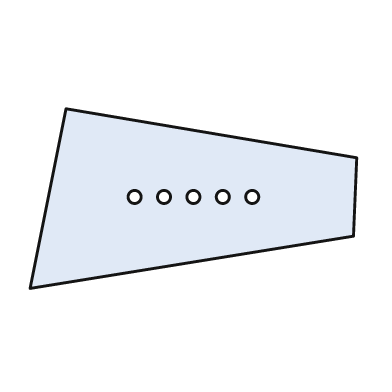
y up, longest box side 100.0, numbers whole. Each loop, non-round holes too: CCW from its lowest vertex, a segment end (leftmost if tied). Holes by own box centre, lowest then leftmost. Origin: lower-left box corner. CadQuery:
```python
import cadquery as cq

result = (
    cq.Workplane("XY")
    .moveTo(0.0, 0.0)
    .lineTo(99.0, 16.0)
    .lineTo(100.0, 40.0)
    .lineTo(11.0, 55.0)
    .close()
    .moveTo(32.0, 28.0)
    .circle(2.0)
    .moveTo(41.0, 28.0)
    .circle(2.0)
    .moveTo(50.0, 28.0)
    .circle(2.0)
    .moveTo(59.0, 28.0)
    .circle(2.0)
    .moveTo(68.0, 28.0)
    .circle(2.0)
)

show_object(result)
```